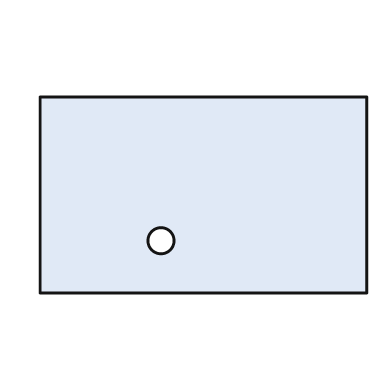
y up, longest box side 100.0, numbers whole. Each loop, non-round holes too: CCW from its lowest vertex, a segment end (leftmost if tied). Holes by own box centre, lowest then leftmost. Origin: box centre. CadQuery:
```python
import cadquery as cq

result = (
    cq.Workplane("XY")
    .moveTo(-50.0, -30.0)
    .lineTo(50.0, -30.0)
    .lineTo(50.0, 30.0)
    .lineTo(-50.0, 30.0)
    .close()
    .moveTo(-13.0, -14.0)
    .circle(4.0)
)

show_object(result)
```